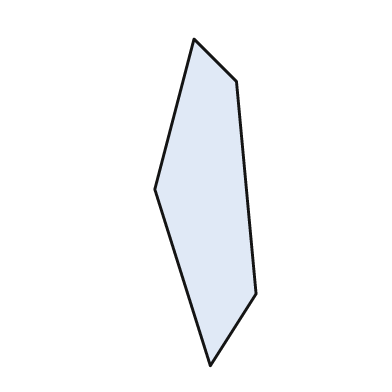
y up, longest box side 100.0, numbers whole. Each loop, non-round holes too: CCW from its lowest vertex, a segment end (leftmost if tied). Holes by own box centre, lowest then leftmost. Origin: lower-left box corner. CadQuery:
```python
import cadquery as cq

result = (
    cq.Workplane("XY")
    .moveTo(17.0, 0.0)
    .lineTo(31.0, 22.0)
    .lineTo(25.0, 87.0)
    .lineTo(12.0, 100.0)
    .lineTo(0.0, 54.0)
    .close()
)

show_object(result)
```